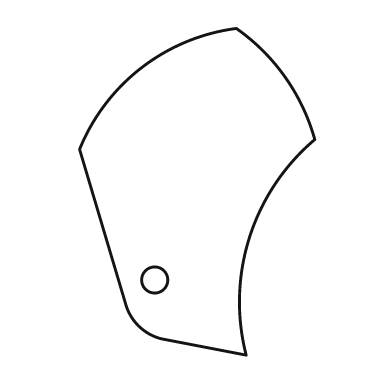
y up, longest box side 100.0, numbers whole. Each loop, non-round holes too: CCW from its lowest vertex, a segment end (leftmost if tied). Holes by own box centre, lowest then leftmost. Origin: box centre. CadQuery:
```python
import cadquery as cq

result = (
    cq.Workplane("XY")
    .moveTo(15.0, -50.0)
    .threePointArc((16.0, -14.0), (36.0, 16.0))
    .threePointArc((27.0, 35.0), (12.0, 50.0))
    .threePointArc((-17.0, 38.0), (-36.0, 13.0))
    .lineTo(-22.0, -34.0)
    .threePointArc((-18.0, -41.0), (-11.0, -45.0))
    .close()
    .moveTo(-13.0, -27.0)
    .circle(4.0)
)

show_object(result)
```